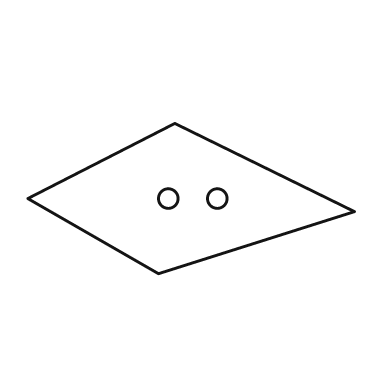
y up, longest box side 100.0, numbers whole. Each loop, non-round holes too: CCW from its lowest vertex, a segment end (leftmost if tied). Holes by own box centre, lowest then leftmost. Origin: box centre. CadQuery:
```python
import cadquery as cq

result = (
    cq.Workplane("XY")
    .moveTo(-10.0, -23.0)
    .lineTo(50.0, -4.0)
    .lineTo(-5.0, 23.0)
    .lineTo(-50.0, 0.0)
    .close()
    .moveTo(-7.0, 0.0)
    .circle(3.0)
    .moveTo(8.0, 0.0)
    .circle(3.0)
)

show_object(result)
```